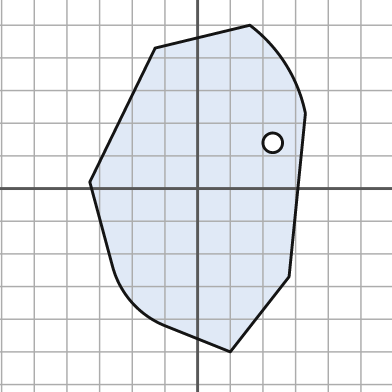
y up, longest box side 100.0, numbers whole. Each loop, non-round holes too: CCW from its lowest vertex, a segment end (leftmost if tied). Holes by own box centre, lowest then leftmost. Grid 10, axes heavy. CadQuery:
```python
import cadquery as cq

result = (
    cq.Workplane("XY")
    .moveTo(10.0, -50.0)
    .lineTo(28.0, -27.0)
    .lineTo(33.0, 23.0)
    .threePointArc((27.0, 38.0), (16.0, 50.0))
    .lineTo(-13.0, 43.0)
    .lineTo(-33.0, 2.0)
    .lineTo(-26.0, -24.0)
    .threePointArc((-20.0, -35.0), (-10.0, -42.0))
    .close()
    .moveTo(23.0, 14.0)
    .circle(3.0)
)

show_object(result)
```